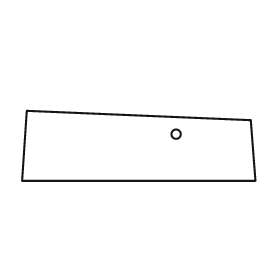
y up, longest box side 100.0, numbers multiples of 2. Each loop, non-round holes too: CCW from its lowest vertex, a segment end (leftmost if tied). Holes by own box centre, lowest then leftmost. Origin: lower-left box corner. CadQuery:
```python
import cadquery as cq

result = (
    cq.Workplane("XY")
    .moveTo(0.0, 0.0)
    .lineTo(100.0, 0.0)
    .lineTo(98.0, 26.0)
    .lineTo(2.0, 30.0)
    .close()
    .moveTo(66.0, 20.0)
    .circle(2.0)
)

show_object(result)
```